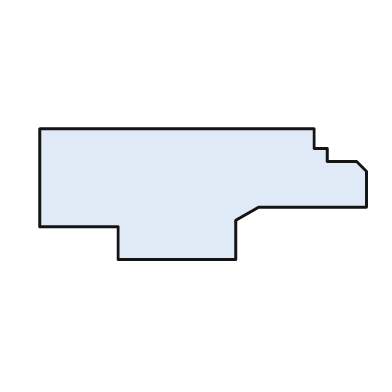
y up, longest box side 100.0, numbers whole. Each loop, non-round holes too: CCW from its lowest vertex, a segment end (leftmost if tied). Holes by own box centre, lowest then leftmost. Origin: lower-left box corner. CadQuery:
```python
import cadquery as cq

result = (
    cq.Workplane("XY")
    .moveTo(24.0, 0.0)
    .lineTo(60.0, 0.0)
    .lineTo(60.0, 12.0)
    .lineTo(67.0, 16.0)
    .lineTo(100.0, 16.0)
    .lineTo(100.0, 27.0)
    .lineTo(97.0, 30.0)
    .lineTo(88.0, 30.0)
    .lineTo(88.0, 34.0)
    .lineTo(84.0, 34.0)
    .lineTo(84.0, 40.0)
    .lineTo(0.0, 40.0)
    .lineTo(0.0, 10.0)
    .lineTo(24.0, 10.0)
    .close()
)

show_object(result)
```